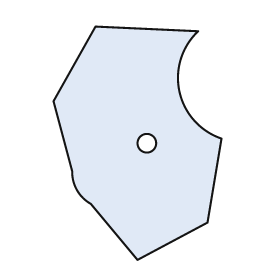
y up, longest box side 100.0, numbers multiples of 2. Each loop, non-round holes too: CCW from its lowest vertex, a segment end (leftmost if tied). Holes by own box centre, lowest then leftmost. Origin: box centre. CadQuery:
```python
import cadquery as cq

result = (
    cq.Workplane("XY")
    .moveTo(0.0, -50.0)
    .lineTo(30.0, -34.0)
    .lineTo(36.0, 2.0)
    .threePointArc((18.0, 22.0), (26.0, 48.0))
    .lineTo(-18.0, 50.0)
    .lineTo(-36.0, 18.0)
    .lineTo(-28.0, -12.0)
    .threePointArc((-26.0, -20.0), (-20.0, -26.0))
    .close()
    .moveTo(4.0, 0.0)
    .circle(4.0)
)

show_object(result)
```